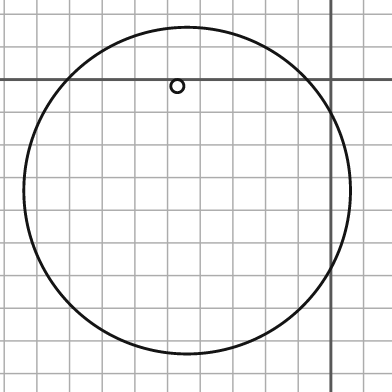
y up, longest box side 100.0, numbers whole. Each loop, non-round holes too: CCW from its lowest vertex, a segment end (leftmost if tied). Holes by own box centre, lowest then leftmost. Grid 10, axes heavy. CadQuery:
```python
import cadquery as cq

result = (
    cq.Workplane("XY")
    .moveTo(-44.0, -34.0)
    .circle(50.0)
    .moveTo(-47.0, -2.0)
    .circle(2.0)
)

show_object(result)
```